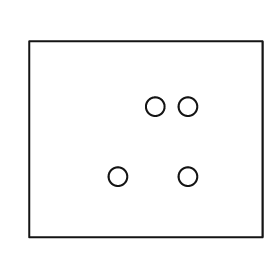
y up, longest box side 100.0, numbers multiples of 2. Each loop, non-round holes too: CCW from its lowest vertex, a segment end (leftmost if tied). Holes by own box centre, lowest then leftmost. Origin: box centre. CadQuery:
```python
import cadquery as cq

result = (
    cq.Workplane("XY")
    .moveTo(-50.0, -42.0)
    .lineTo(50.0, -42.0)
    .lineTo(50.0, 42.0)
    .lineTo(-50.0, 42.0)
    .close()
    .moveTo(-12.0, -16.0)
    .circle(4.0)
    .moveTo(18.0, -16.0)
    .circle(4.0)
    .moveTo(4.0, 14.0)
    .circle(4.0)
    .moveTo(18.0, 14.0)
    .circle(4.0)
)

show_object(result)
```